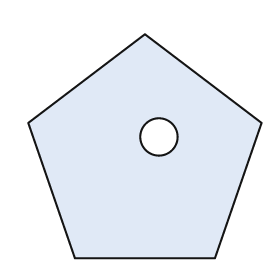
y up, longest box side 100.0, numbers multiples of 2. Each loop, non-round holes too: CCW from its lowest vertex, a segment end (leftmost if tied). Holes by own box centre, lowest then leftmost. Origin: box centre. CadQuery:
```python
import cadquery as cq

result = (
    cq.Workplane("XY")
    .moveTo(-30.0, -48.0)
    .lineTo(30.0, -48.0)
    .lineTo(50.0, 10.0)
    .lineTo(0.0, 48.0)
    .lineTo(-50.0, 10.0)
    .close()
    .moveTo(6.0, 4.0)
    .circle(8.0)
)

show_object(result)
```